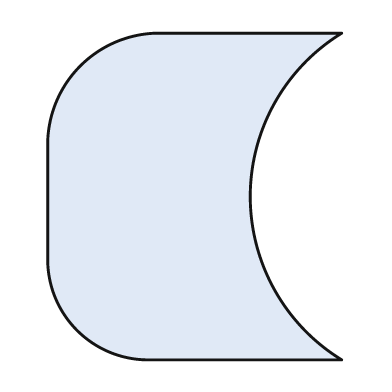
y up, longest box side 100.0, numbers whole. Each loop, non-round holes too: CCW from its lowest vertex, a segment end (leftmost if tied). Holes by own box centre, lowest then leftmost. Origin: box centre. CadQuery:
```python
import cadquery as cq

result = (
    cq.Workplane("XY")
    .moveTo(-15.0, -50.0)
    .lineTo(45.0, -50.0)
    .threePointArc((17.0, 0.0), (45.0, 50.0))
    .lineTo(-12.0, 50.0)
    .threePointArc((-35.0, 40.0), (-45.0, 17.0))
    .lineTo(-45.0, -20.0)
    .threePointArc((-36.0, -41.0), (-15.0, -50.0))
    .close()
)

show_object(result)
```